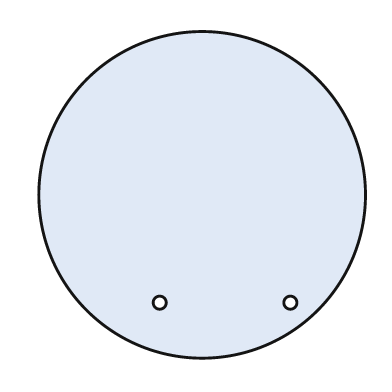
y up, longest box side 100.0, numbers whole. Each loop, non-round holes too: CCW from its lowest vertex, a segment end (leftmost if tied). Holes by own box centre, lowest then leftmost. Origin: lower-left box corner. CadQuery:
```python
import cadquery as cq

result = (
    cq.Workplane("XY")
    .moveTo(50.0, 50.0)
    .circle(50.0)
    .moveTo(37.0, 17.0)
    .circle(2.0)
    .moveTo(77.0, 17.0)
    .circle(2.0)
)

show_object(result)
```